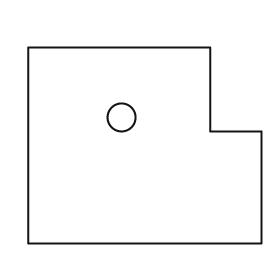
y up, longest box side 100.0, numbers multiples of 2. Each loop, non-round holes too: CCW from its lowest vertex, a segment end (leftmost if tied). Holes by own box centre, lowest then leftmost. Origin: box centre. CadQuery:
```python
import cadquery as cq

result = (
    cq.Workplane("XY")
    .moveTo(-50.0, -42.0)
    .lineTo(50.0, -42.0)
    .lineTo(50.0, 6.0)
    .lineTo(28.0, 6.0)
    .lineTo(28.0, 42.0)
    .lineTo(-50.0, 42.0)
    .close()
    .moveTo(-10.0, 12.0)
    .circle(6.0)
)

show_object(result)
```